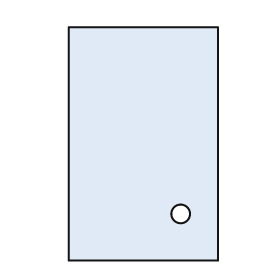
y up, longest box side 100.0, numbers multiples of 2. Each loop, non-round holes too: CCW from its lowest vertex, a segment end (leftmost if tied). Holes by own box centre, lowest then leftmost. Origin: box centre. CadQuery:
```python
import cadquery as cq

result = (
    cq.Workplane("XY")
    .moveTo(-32.0, -50.0)
    .lineTo(32.0, -50.0)
    .lineTo(32.0, 50.0)
    .lineTo(-32.0, 50.0)
    .close()
    .moveTo(16.0, -30.0)
    .circle(4.0)
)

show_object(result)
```